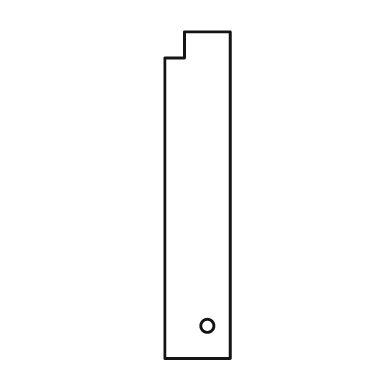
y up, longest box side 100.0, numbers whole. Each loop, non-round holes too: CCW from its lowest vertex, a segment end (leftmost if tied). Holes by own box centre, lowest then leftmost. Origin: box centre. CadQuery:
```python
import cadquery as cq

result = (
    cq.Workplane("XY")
    .moveTo(-10.0, -50.0)
    .lineTo(10.0, -50.0)
    .lineTo(10.0, 50.0)
    .lineTo(-4.0, 50.0)
    .lineTo(-4.0, 42.0)
    .lineTo(-10.0, 42.0)
    .close()
    .moveTo(3.0, -40.0)
    .circle(2.0)
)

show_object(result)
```